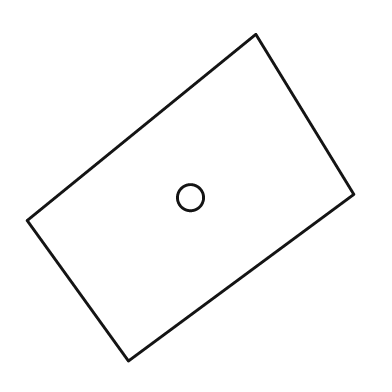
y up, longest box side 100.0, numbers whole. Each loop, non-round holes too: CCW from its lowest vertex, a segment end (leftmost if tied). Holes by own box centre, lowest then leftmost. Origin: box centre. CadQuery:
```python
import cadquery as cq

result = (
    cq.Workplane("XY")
    .moveTo(-19.0, -50.0)
    .lineTo(50.0, 1.0)
    .lineTo(20.0, 50.0)
    .lineTo(-50.0, -7.0)
    .close()
    .moveTo(0.0, 0.0)
    .circle(4.0)
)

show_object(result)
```